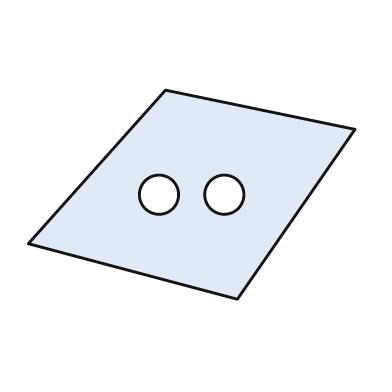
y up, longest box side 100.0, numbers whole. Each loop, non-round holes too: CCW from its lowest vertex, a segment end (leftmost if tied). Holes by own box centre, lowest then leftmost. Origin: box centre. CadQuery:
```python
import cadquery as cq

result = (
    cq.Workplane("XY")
    .moveTo(14.0, -32.0)
    .lineTo(50.0, 20.0)
    .lineTo(-8.0, 32.0)
    .lineTo(-50.0, -15.0)
    .close()
    .moveTo(-10.0, 0.0)
    .circle(6.0)
    .moveTo(10.0, 0.0)
    .circle(6.0)
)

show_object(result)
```